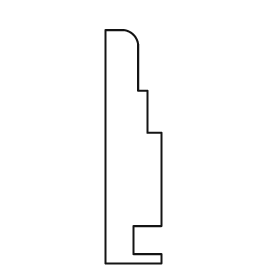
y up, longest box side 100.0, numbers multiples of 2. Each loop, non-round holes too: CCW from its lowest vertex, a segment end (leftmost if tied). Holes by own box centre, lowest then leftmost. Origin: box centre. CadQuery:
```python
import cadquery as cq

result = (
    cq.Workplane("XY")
    .moveTo(-12.0, -50.0)
    .lineTo(12.0, -50.0)
    .lineTo(12.0, -46.0)
    .lineTo(0.0, -46.0)
    .lineTo(0.0, -34.0)
    .lineTo(12.0, -34.0)
    .lineTo(12.0, 6.0)
    .lineTo(6.0, 6.0)
    .lineTo(6.0, 24.0)
    .lineTo(2.0, 24.0)
    .lineTo(2.0, 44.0)
    .threePointArc((0.0, 48.0), (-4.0, 50.0))
    .lineTo(-12.0, 50.0)
    .close()
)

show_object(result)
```